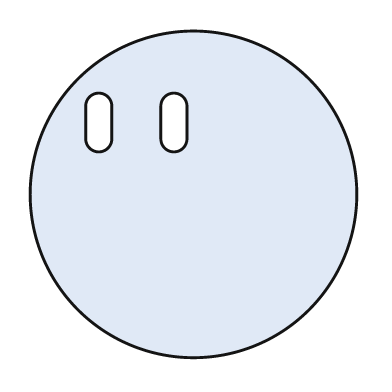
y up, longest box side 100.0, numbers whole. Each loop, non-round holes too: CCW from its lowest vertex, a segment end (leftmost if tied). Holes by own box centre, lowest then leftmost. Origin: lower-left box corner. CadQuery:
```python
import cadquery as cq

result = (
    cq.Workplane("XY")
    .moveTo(50.0, 50.0)
    .circle(50.0)
    .moveTo(17.0, 67.0)
    .threePointArc((21.0, 63.0), (25.0, 67.0))
    .lineTo(25.0, 77.0)
    .threePointArc((21.0, 81.0), (17.0, 77.0))
    .close()
    .moveTo(40.0, 67.0)
    .threePointArc((44.0, 63.0), (48.0, 67.0))
    .lineTo(48.0, 77.0)
    .threePointArc((44.0, 81.0), (40.0, 77.0))
    .close()
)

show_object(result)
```